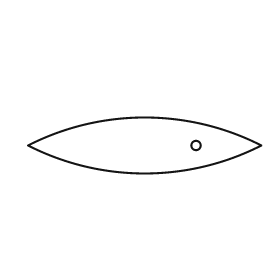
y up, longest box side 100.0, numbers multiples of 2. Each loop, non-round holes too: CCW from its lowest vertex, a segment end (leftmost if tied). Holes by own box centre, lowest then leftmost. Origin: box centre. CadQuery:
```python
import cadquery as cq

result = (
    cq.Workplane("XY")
    .moveTo(-50.0, 0.0)
    .threePointArc((0.0, -12.0), (50.0, 0.0))
    .threePointArc((0.0, 12.0), (-50.0, 0.0))
    .close()
    .moveTo(22.0, 0.0)
    .circle(2.0)
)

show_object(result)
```